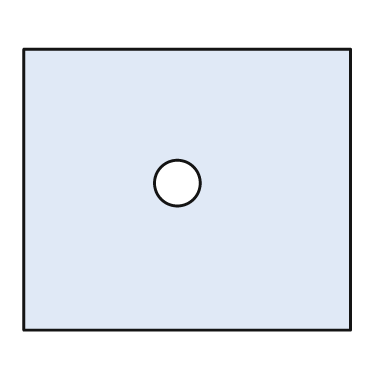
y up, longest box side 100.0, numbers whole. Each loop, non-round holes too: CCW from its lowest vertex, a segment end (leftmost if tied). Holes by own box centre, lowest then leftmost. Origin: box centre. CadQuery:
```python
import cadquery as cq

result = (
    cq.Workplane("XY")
    .moveTo(-50.0, -43.0)
    .lineTo(50.0, -43.0)
    .lineTo(50.0, 43.0)
    .lineTo(-50.0, 43.0)
    .close()
    .moveTo(-3.0, 2.0)
    .circle(7.0)
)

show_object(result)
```